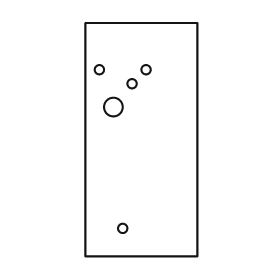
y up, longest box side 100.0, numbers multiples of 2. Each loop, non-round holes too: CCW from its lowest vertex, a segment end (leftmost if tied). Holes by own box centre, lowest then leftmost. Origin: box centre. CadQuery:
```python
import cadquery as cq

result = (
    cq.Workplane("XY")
    .moveTo(-24.0, -50.0)
    .lineTo(24.0, -50.0)
    .lineTo(24.0, 50.0)
    .lineTo(-24.0, 50.0)
    .close()
    .moveTo(-8.0, -38.0)
    .circle(2.0)
    .moveTo(-12.0, 14.0)
    .circle(4.0)
    .moveTo(-4.0, 24.0)
    .circle(2.0)
    .moveTo(-18.0, 30.0)
    .circle(2.0)
    .moveTo(2.0, 30.0)
    .circle(2.0)
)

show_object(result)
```